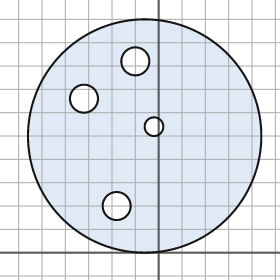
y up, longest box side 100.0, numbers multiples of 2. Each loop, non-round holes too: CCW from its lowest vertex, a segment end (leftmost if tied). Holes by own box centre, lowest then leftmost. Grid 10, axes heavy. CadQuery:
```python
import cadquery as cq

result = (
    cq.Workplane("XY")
    .moveTo(-6.0, 50.0)
    .circle(50.0)
    .moveTo(-18.0, 20.0)
    .circle(6.0)
    .moveTo(-2.0, 54.0)
    .circle(4.0)
    .moveTo(-32.0, 66.0)
    .circle(6.0)
    .moveTo(-10.0, 82.0)
    .circle(6.0)
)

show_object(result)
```